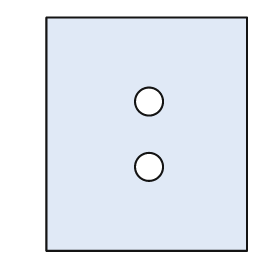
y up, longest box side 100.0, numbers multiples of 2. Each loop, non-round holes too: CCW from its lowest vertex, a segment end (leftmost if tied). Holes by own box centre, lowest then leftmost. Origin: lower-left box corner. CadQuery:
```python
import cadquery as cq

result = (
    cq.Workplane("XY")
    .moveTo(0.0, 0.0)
    .lineTo(86.0, 0.0)
    .lineTo(86.0, 100.0)
    .lineTo(0.0, 100.0)
    .close()
    .moveTo(44.0, 36.0)
    .circle(6.0)
    .moveTo(44.0, 64.0)
    .circle(6.0)
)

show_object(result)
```